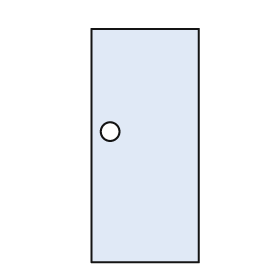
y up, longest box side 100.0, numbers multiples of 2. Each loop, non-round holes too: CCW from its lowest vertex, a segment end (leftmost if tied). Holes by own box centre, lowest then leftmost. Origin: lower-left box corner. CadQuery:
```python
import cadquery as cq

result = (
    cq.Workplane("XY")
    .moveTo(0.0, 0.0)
    .lineTo(46.0, 0.0)
    .lineTo(46.0, 100.0)
    .lineTo(0.0, 100.0)
    .close()
    .moveTo(8.0, 56.0)
    .circle(4.0)
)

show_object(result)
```